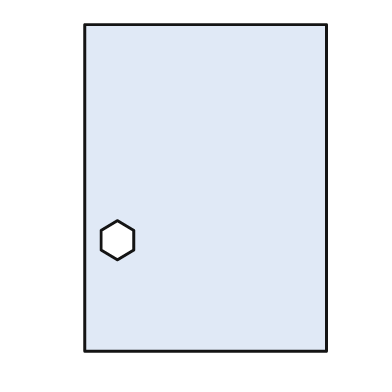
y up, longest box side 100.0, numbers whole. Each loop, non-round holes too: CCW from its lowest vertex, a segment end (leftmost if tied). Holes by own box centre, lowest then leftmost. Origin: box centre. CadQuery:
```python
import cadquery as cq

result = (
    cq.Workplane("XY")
    .moveTo(-37.0, -50.0)
    .lineTo(37.0, -50.0)
    .lineTo(37.0, 50.0)
    .lineTo(-37.0, 50.0)
    .close()
    .moveTo(-27.0, -22.0)
    .lineTo(-22.0, -19.0)
    .lineTo(-22.0, -13.0)
    .lineTo(-27.0, -10.0)
    .lineTo(-32.0, -13.0)
    .lineTo(-32.0, -19.0)
    .close()
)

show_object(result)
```